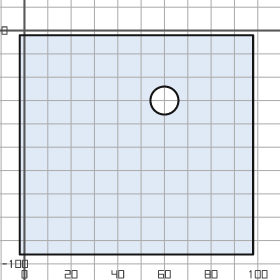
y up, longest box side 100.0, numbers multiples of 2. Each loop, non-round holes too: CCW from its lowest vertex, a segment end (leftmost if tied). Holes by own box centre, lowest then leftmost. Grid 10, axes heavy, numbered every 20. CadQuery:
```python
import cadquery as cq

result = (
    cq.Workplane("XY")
    .moveTo(-2.0, -96.0)
    .lineTo(98.0, -96.0)
    .lineTo(98.0, -2.0)
    .lineTo(-2.0, -2.0)
    .close()
    .moveTo(60.0, -30.0)
    .circle(6.0)
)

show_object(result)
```